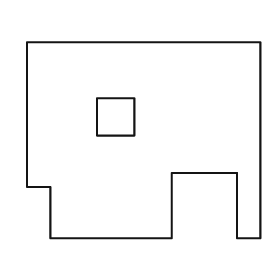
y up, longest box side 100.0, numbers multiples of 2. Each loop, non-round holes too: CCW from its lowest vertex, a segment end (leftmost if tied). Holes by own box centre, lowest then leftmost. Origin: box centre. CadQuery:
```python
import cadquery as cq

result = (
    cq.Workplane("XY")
    .moveTo(-40.0, -42.0)
    .lineTo(12.0, -42.0)
    .lineTo(12.0, -14.0)
    .lineTo(40.0, -14.0)
    .lineTo(40.0, -42.0)
    .lineTo(50.0, -42.0)
    .lineTo(50.0, 42.0)
    .lineTo(-50.0, 42.0)
    .lineTo(-50.0, -20.0)
    .lineTo(-40.0, -20.0)
    .close()
    .moveTo(-20.0, 2.0)
    .lineTo(-4.0, 2.0)
    .lineTo(-4.0, 18.0)
    .lineTo(-20.0, 18.0)
    .close()
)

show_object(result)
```